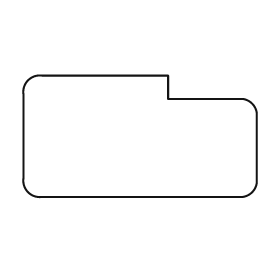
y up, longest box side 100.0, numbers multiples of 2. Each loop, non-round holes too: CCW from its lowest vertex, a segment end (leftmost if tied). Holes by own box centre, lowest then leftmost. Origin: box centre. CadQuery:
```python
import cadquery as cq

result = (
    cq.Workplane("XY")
    .moveTo(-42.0, -26.0)
    .lineTo(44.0, -26.0)
    .threePointArc((48.0, -24.0), (50.0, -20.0))
    .lineTo(50.0, 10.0)
    .threePointArc((48.0, 14.0), (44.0, 16.0))
    .lineTo(12.0, 16.0)
    .lineTo(12.0, 26.0)
    .lineTo(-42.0, 26.0)
    .threePointArc((-48.0, 24.0), (-50.0, 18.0))
    .lineTo(-50.0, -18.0)
    .threePointArc((-48.0, -24.0), (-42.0, -26.0))
    .close()
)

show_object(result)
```